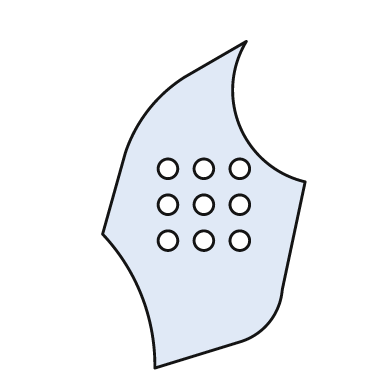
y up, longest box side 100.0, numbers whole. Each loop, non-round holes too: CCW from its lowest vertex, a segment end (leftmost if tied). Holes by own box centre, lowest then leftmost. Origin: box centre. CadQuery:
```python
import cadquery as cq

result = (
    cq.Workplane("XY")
    .moveTo(-15.0, -50.0)
    .lineTo(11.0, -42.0)
    .threePointArc((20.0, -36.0), (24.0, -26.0))
    .lineTo(31.0, 7.0)
    .threePointArc((11.0, 24.0), (13.0, 50.0))
    .lineTo(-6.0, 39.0)
    .threePointArc((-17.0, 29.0), (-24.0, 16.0))
    .lineTo(-31.0, -9.0)
    .threePointArc((-19.0, -28.0), (-15.0, -50.0))
    .close()
    .moveTo(-11.0, -11.0)
    .circle(3.0)
    .moveTo(0.0, -11.0)
    .circle(3.0)
    .moveTo(11.0, -11.0)
    .circle(3.0)
    .moveTo(-11.0, 0.0)
    .circle(3.0)
    .moveTo(0.0, 0.0)
    .circle(3.0)
    .moveTo(11.0, 0.0)
    .circle(3.0)
    .moveTo(-11.0, 11.0)
    .circle(3.0)
    .moveTo(0.0, 11.0)
    .circle(3.0)
    .moveTo(11.0, 11.0)
    .circle(3.0)
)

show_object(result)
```